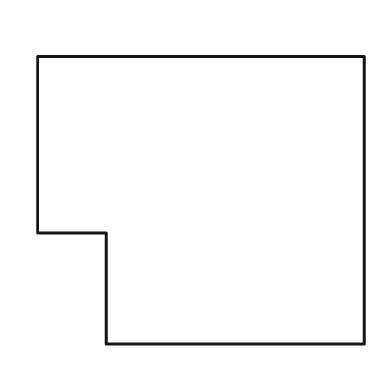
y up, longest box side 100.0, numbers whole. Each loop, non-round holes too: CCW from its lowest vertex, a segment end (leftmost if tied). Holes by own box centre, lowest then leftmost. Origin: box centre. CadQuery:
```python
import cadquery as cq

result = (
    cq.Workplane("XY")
    .moveTo(-29.0, -44.0)
    .lineTo(50.0, -44.0)
    .lineTo(50.0, 44.0)
    .lineTo(-50.0, 44.0)
    .lineTo(-50.0, -10.0)
    .lineTo(-29.0, -10.0)
    .close()
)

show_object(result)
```